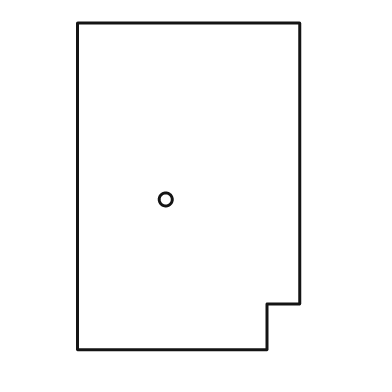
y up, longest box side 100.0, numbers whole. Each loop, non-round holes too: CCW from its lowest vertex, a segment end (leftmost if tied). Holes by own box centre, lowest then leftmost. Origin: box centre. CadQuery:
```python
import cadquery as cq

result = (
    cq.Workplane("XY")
    .moveTo(-34.0, -50.0)
    .lineTo(24.0, -50.0)
    .lineTo(24.0, -36.0)
    .lineTo(34.0, -36.0)
    .lineTo(34.0, 50.0)
    .lineTo(-34.0, 50.0)
    .close()
    .moveTo(-7.0, -4.0)
    .circle(2.0)
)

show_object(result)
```